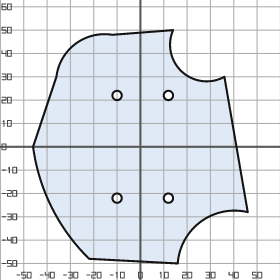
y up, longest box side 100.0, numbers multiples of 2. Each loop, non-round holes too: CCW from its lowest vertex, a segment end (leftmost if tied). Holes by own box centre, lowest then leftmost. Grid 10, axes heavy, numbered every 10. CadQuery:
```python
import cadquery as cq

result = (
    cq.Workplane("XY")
    .moveTo(16.0, -50.0)
    .threePointArc((26.0, -32.0), (46.0, -28.0))
    .lineTo(36.0, 30.0)
    .threePointArc((18.0, 32.0), (14.0, 50.0))
    .lineTo(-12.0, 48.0)
    .threePointArc((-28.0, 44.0), (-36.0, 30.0))
    .lineTo(-46.0, 0.0)
    .threePointArc((-38.0, -26.0), (-22.0, -48.0))
    .close()
    .moveTo(-10.0, -22.0)
    .circle(2.0)
    .moveTo(12.0, -22.0)
    .circle(2.0)
    .moveTo(-10.0, 22.0)
    .circle(2.0)
    .moveTo(12.0, 22.0)
    .circle(2.0)
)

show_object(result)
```